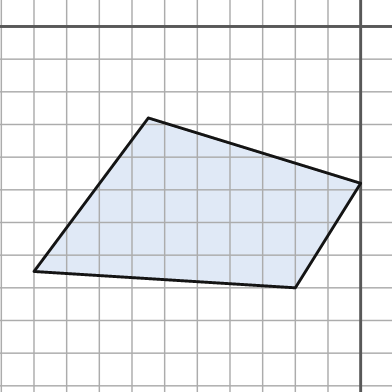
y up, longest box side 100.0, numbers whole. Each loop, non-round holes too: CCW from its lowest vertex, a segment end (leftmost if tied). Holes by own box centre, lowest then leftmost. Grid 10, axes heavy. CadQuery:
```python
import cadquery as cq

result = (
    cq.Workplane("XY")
    .moveTo(-20.0, -80.0)
    .lineTo(0.0, -48.0)
    .lineTo(-65.0, -28.0)
    .lineTo(-100.0, -75.0)
    .close()
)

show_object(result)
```